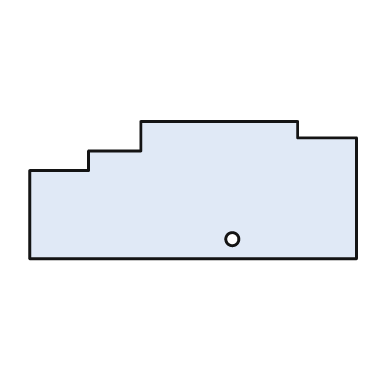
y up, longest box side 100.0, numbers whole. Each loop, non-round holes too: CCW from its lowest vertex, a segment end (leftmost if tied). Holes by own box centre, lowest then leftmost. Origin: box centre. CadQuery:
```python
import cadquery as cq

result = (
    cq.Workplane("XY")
    .moveTo(-50.0, -21.0)
    .lineTo(50.0, -21.0)
    .lineTo(50.0, 16.0)
    .lineTo(32.0, 16.0)
    .lineTo(32.0, 21.0)
    .lineTo(-16.0, 21.0)
    .lineTo(-16.0, 12.0)
    .lineTo(-32.0, 12.0)
    .lineTo(-32.0, 6.0)
    .lineTo(-50.0, 6.0)
    .close()
    .moveTo(12.0, -15.0)
    .circle(2.0)
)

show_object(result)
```